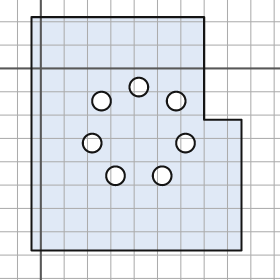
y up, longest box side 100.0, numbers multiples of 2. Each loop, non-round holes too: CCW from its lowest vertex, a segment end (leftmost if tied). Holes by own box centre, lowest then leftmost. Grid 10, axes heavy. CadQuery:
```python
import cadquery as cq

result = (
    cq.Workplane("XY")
    .moveTo(-4.0, -78.0)
    .lineTo(86.0, -78.0)
    .lineTo(86.0, -22.0)
    .lineTo(70.0, -22.0)
    .lineTo(70.0, 22.0)
    .lineTo(-4.0, 22.0)
    .close()
    .moveTo(32.0, -46.0)
    .circle(4.0)
    .moveTo(52.0, -46.0)
    .circle(4.0)
    .moveTo(22.0, -32.0)
    .circle(4.0)
    .moveTo(62.0, -32.0)
    .circle(4.0)
    .moveTo(26.0, -14.0)
    .circle(4.0)
    .moveTo(58.0, -14.0)
    .circle(4.0)
    .moveTo(42.0, -8.0)
    .circle(4.0)
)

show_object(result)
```